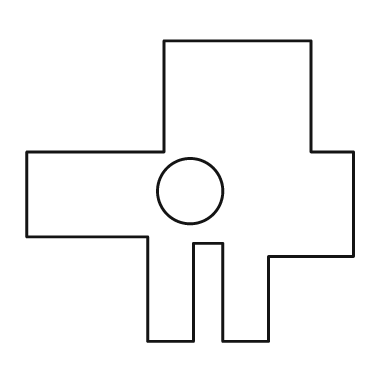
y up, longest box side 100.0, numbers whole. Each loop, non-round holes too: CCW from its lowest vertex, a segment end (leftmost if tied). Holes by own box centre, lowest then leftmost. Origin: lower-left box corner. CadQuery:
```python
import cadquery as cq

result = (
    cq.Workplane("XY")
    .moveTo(37.0, 0.0)
    .lineTo(51.0, 0.0)
    .lineTo(51.0, 30.0)
    .lineTo(60.0, 30.0)
    .lineTo(60.0, 0.0)
    .lineTo(74.0, 0.0)
    .lineTo(74.0, 26.0)
    .lineTo(100.0, 26.0)
    .lineTo(100.0, 58.0)
    .lineTo(87.0, 58.0)
    .lineTo(87.0, 92.0)
    .lineTo(42.0, 92.0)
    .lineTo(42.0, 58.0)
    .lineTo(0.0, 58.0)
    .lineTo(0.0, 32.0)
    .lineTo(37.0, 32.0)
    .close()
    .moveTo(50.0, 46.0)
    .circle(10.0)
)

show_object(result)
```